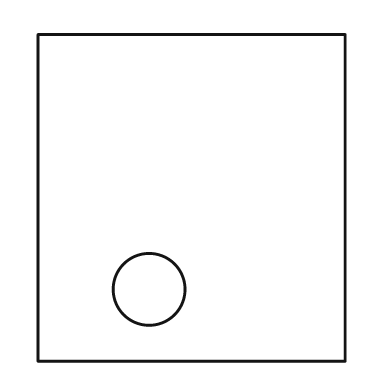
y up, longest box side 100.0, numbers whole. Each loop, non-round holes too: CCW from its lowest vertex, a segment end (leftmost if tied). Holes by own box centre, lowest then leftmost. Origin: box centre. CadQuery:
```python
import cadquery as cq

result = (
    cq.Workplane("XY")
    .moveTo(-47.0, -50.0)
    .lineTo(47.0, -50.0)
    .lineTo(47.0, 50.0)
    .lineTo(-47.0, 50.0)
    .close()
    .moveTo(-13.0, -28.0)
    .circle(11.0)
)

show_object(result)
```